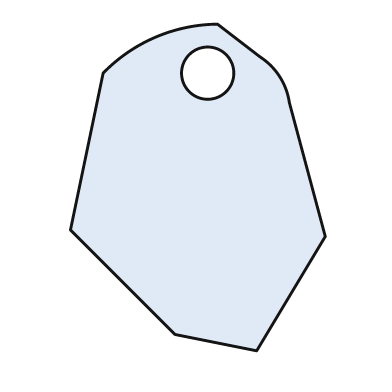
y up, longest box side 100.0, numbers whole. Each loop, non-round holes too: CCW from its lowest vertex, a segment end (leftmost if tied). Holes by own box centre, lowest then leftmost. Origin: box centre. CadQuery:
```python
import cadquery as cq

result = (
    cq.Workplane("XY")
    .moveTo(18.0, -50.0)
    .lineTo(39.0, -15.0)
    .lineTo(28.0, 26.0)
    .threePointArc((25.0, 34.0), (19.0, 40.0))
    .lineTo(6.0, 50.0)
    .threePointArc((-13.0, 46.0), (-29.0, 35.0))
    .lineTo(-39.0, -13.0)
    .lineTo(-7.0, -45.0)
    .close()
    .moveTo(3.0, 35.0)
    .circle(8.0)
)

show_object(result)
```